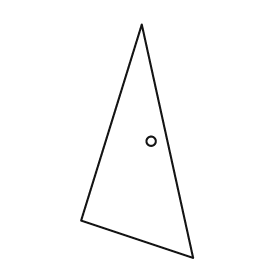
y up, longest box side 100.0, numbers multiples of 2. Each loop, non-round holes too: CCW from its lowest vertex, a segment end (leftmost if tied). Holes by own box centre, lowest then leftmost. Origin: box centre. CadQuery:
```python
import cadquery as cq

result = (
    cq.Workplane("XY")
    .moveTo(24.0, -50.0)
    .lineTo(2.0, 50.0)
    .lineTo(-24.0, -34.0)
    .close()
    .moveTo(6.0, 0.0)
    .circle(2.0)
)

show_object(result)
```